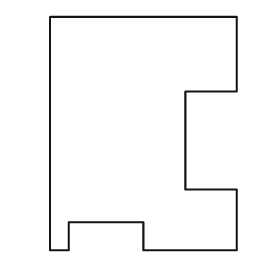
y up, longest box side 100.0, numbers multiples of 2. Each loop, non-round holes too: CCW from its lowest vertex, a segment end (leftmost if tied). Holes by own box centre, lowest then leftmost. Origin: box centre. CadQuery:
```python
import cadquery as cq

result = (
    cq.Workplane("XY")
    .moveTo(-40.0, -50.0)
    .lineTo(-32.0, -50.0)
    .lineTo(-32.0, -38.0)
    .lineTo(0.0, -38.0)
    .lineTo(0.0, -50.0)
    .lineTo(40.0, -50.0)
    .lineTo(40.0, -24.0)
    .lineTo(18.0, -24.0)
    .lineTo(18.0, 18.0)
    .lineTo(40.0, 18.0)
    .lineTo(40.0, 50.0)
    .lineTo(-40.0, 50.0)
    .close()
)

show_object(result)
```